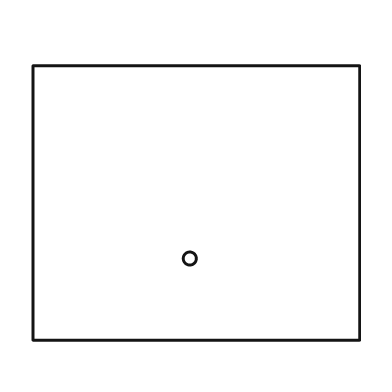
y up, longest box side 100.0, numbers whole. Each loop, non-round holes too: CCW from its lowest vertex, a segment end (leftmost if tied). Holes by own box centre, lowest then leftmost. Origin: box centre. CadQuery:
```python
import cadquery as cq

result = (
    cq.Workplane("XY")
    .moveTo(-50.0, -42.0)
    .lineTo(50.0, -42.0)
    .lineTo(50.0, 42.0)
    .lineTo(-50.0, 42.0)
    .close()
    .moveTo(-2.0, -17.0)
    .circle(2.0)
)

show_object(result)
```